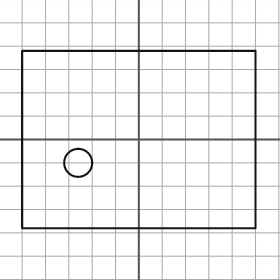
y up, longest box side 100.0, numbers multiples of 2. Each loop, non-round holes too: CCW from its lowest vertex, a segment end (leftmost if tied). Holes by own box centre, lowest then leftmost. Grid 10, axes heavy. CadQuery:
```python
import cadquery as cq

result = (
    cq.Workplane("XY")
    .moveTo(-50.0, -38.0)
    .lineTo(50.0, -38.0)
    .lineTo(50.0, 38.0)
    .lineTo(-50.0, 38.0)
    .close()
    .moveTo(-26.0, -10.0)
    .circle(6.0)
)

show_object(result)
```